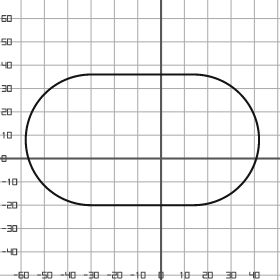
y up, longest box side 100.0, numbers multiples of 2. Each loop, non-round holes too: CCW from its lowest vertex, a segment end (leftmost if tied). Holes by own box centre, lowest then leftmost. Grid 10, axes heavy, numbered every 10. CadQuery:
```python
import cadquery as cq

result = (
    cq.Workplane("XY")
    .moveTo(-30.0, -20.0)
    .lineTo(14.0, -20.0)
    .threePointArc((42.0, 8.0), (14.0, 36.0))
    .lineTo(-30.0, 36.0)
    .threePointArc((-58.0, 8.0), (-30.0, -20.0))
    .close()
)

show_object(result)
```